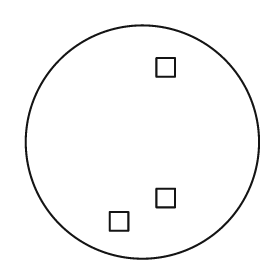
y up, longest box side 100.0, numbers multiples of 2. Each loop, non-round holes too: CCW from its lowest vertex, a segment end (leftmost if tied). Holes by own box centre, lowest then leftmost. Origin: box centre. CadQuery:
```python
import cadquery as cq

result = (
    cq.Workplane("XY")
    .moveTo(0.0, 0.0)
    .circle(50.0)
    .moveTo(-14.0, -38.0)
    .lineTo(-6.0, -38.0)
    .lineTo(-6.0, -30.0)
    .lineTo(-14.0, -30.0)
    .close()
    .moveTo(6.0, -28.0)
    .lineTo(14.0, -28.0)
    .lineTo(14.0, -20.0)
    .lineTo(6.0, -20.0)
    .close()
    .moveTo(6.0, 28.0)
    .lineTo(14.0, 28.0)
    .lineTo(14.0, 36.0)
    .lineTo(6.0, 36.0)
    .close()
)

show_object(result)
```